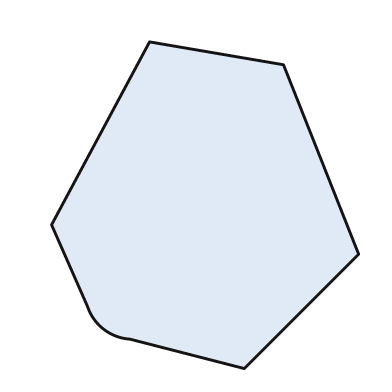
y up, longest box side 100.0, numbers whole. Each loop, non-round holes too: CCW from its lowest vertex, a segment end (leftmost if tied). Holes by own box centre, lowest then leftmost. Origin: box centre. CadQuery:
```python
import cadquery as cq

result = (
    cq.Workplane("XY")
    .moveTo(12.0, -50.0)
    .lineTo(47.0, -15.0)
    .lineTo(24.0, 43.0)
    .lineTo(-17.0, 50.0)
    .lineTo(-47.0, -6.0)
    .lineTo(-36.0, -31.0)
    .threePointArc((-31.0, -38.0), (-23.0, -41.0))
    .close()
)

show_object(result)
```